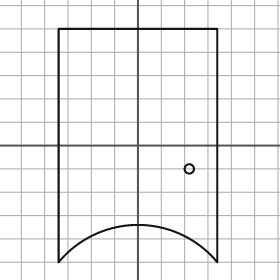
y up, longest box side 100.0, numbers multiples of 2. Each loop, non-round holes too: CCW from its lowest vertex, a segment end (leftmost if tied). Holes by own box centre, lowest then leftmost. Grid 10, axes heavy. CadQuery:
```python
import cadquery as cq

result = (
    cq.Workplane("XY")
    .moveTo(-34.0, -50.0)
    .threePointArc((0.0, -34.0), (34.0, -50.0))
    .lineTo(34.0, 50.0)
    .lineTo(-34.0, 50.0)
    .close()
    .moveTo(22.0, -10.0)
    .circle(2.0)
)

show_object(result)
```